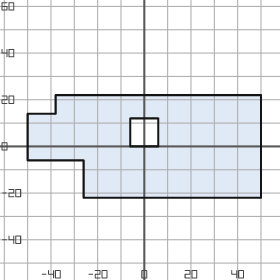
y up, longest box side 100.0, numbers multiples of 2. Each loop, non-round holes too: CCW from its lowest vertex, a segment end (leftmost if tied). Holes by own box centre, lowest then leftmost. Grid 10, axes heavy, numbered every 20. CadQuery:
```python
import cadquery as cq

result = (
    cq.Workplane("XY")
    .moveTo(-26.0, -22.0)
    .lineTo(50.0, -22.0)
    .lineTo(50.0, 22.0)
    .lineTo(-38.0, 22.0)
    .lineTo(-38.0, 14.0)
    .lineTo(-50.0, 14.0)
    .lineTo(-50.0, -6.0)
    .lineTo(-26.0, -6.0)
    .close()
    .moveTo(-6.0, 0.0)
    .lineTo(6.0, 0.0)
    .lineTo(6.0, 12.0)
    .lineTo(-6.0, 12.0)
    .close()
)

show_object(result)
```